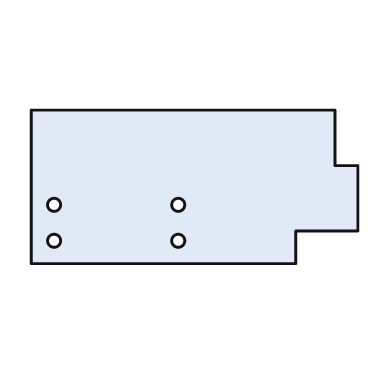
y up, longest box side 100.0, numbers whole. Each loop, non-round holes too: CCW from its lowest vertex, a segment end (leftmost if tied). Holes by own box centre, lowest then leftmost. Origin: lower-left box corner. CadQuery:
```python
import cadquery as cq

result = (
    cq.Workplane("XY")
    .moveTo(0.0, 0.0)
    .lineTo(81.0, 0.0)
    .lineTo(81.0, 10.0)
    .lineTo(100.0, 10.0)
    .lineTo(100.0, 30.0)
    .lineTo(93.0, 30.0)
    .lineTo(93.0, 47.0)
    .lineTo(0.0, 47.0)
    .close()
    .moveTo(7.0, 7.0)
    .circle(2.0)
    .moveTo(45.0, 7.0)
    .circle(2.0)
    .moveTo(7.0, 18.0)
    .circle(2.0)
    .moveTo(45.0, 18.0)
    .circle(2.0)
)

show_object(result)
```